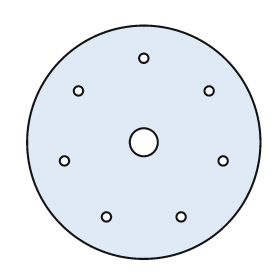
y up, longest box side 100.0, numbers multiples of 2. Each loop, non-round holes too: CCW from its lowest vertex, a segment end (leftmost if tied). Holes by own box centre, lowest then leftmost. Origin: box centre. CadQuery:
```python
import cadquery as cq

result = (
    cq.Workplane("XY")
    .moveTo(0.0, 0.0)
    .circle(50.0)
    .moveTo(-16.0, -32.0)
    .circle(2.0)
    .moveTo(16.0, -32.0)
    .circle(2.0)
    .moveTo(-34.0, -8.0)
    .circle(2.0)
    .moveTo(34.0, -8.0)
    .circle(2.0)
    .moveTo(0.0, 0.0)
    .circle(6.0)
    .moveTo(-28.0, 22.0)
    .circle(2.0)
    .moveTo(28.0, 22.0)
    .circle(2.0)
    .moveTo(0.0, 36.0)
    .circle(2.0)
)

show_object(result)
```